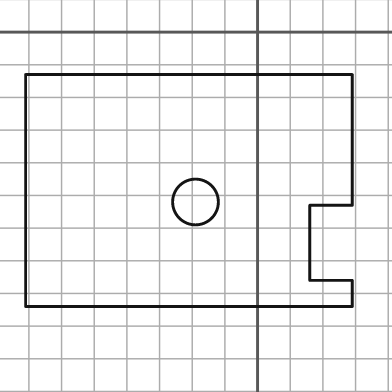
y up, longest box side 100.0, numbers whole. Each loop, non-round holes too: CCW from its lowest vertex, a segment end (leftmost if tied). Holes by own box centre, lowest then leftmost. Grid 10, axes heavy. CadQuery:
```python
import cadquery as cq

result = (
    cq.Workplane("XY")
    .moveTo(-71.0, -84.0)
    .lineTo(29.0, -84.0)
    .lineTo(29.0, -76.0)
    .lineTo(16.0, -76.0)
    .lineTo(16.0, -53.0)
    .lineTo(29.0, -53.0)
    .lineTo(29.0, -13.0)
    .lineTo(-71.0, -13.0)
    .close()
    .moveTo(-19.0, -52.0)
    .circle(7.0)
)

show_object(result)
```